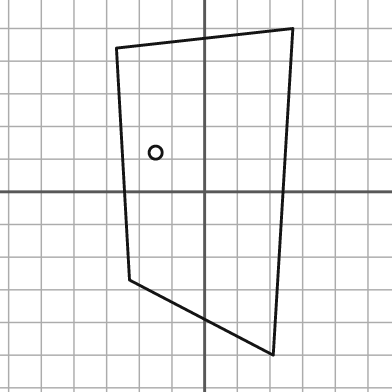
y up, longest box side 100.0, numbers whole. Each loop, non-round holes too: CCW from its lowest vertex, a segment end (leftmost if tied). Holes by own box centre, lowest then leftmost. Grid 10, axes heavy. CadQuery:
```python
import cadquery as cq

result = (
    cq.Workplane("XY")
    .moveTo(21.0, -50.0)
    .lineTo(27.0, 50.0)
    .lineTo(-27.0, 44.0)
    .lineTo(-23.0, -27.0)
    .close()
    .moveTo(-15.0, 12.0)
    .circle(2.0)
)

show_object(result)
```